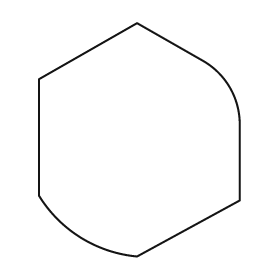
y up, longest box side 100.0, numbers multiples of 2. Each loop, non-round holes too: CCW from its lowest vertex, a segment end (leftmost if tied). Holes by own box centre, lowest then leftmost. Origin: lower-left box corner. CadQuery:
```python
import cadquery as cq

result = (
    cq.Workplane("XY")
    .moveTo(42.0, 0.0)
    .lineTo(86.0, 24.0)
    .lineTo(86.0, 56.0)
    .threePointArc((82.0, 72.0), (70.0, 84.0))
    .lineTo(42.0, 100.0)
    .lineTo(0.0, 76.0)
    .lineTo(0.0, 26.0)
    .threePointArc((18.0, 8.0), (42.0, 0.0))
    .close()
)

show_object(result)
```